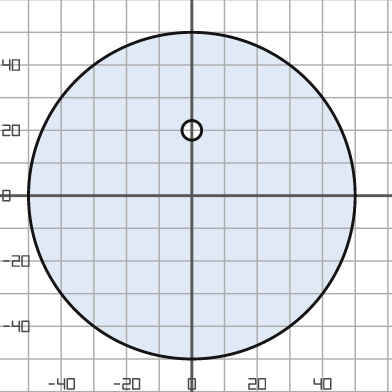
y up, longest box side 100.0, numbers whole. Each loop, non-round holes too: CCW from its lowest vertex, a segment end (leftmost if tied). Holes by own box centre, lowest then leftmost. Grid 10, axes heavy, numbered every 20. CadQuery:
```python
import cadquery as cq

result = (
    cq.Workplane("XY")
    .moveTo(0.0, 0.0)
    .circle(50.0)
    .moveTo(0.0, 20.0)
    .circle(3.0)
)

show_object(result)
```